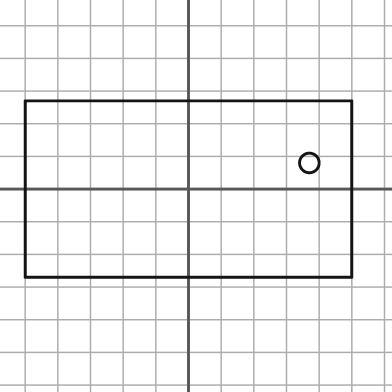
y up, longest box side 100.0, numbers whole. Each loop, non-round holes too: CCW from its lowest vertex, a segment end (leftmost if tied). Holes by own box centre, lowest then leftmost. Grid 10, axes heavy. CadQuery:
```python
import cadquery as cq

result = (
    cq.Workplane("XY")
    .moveTo(-50.0, -27.0)
    .lineTo(50.0, -27.0)
    .lineTo(50.0, 27.0)
    .lineTo(-50.0, 27.0)
    .close()
    .moveTo(37.0, 8.0)
    .circle(3.0)
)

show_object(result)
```